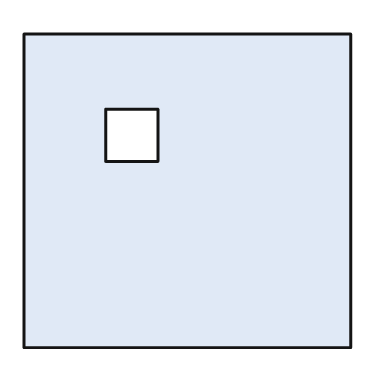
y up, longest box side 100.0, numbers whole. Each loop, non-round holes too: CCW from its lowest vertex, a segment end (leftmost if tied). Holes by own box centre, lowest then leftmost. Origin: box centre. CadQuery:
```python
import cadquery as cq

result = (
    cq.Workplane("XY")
    .moveTo(-50.0, -48.0)
    .lineTo(50.0, -48.0)
    .lineTo(50.0, 48.0)
    .lineTo(-50.0, 48.0)
    .close()
    .moveTo(-25.0, 9.0)
    .lineTo(-9.0, 9.0)
    .lineTo(-9.0, 25.0)
    .lineTo(-25.0, 25.0)
    .close()
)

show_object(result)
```